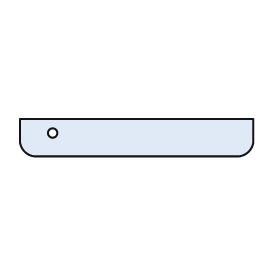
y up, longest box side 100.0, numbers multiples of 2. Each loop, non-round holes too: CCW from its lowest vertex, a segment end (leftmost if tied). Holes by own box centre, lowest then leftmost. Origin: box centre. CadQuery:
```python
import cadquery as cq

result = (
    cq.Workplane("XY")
    .moveTo(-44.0, -8.0)
    .lineTo(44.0, -8.0)
    .threePointArc((48.0, -6.0), (50.0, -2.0))
    .lineTo(50.0, 8.0)
    .lineTo(-50.0, 8.0)
    .lineTo(-50.0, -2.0)
    .threePointArc((-48.0, -6.0), (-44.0, -8.0))
    .close()
    .moveTo(-36.0, 2.0)
    .circle(2.0)
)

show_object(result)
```